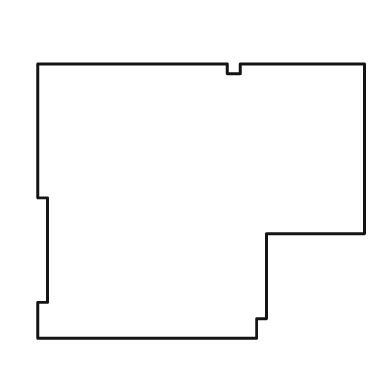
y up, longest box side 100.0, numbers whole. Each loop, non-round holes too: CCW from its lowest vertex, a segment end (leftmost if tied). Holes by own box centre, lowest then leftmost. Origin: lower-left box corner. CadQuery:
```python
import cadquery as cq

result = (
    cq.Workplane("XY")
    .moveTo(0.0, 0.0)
    .lineTo(67.0, 0.0)
    .lineTo(67.0, 6.0)
    .lineTo(70.0, 6.0)
    .lineTo(70.0, 32.0)
    .lineTo(100.0, 32.0)
    .lineTo(100.0, 84.0)
    .lineTo(62.0, 84.0)
    .lineTo(62.0, 81.0)
    .lineTo(58.0, 81.0)
    .lineTo(58.0, 84.0)
    .lineTo(0.0, 84.0)
    .lineTo(0.0, 43.0)
    .lineTo(3.0, 43.0)
    .lineTo(3.0, 11.0)
    .lineTo(0.0, 11.0)
    .close()
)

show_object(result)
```